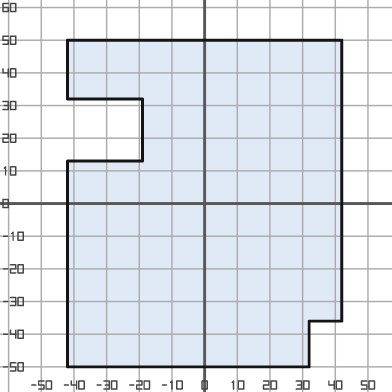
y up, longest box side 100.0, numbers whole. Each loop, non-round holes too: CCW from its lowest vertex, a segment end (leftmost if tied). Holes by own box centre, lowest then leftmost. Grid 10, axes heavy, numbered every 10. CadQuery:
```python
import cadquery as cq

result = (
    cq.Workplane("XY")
    .moveTo(-42.0, -50.0)
    .lineTo(32.0, -50.0)
    .lineTo(32.0, -36.0)
    .lineTo(42.0, -36.0)
    .lineTo(42.0, 50.0)
    .lineTo(-42.0, 50.0)
    .lineTo(-42.0, 32.0)
    .lineTo(-19.0, 32.0)
    .lineTo(-19.0, 13.0)
    .lineTo(-42.0, 13.0)
    .close()
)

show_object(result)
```